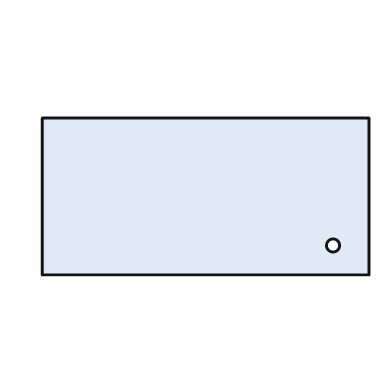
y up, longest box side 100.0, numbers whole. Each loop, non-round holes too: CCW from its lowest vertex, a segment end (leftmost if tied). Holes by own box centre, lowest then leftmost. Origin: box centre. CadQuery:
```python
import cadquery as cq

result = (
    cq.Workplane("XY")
    .moveTo(-50.0, -24.0)
    .lineTo(50.0, -24.0)
    .lineTo(50.0, 24.0)
    .lineTo(-50.0, 24.0)
    .close()
    .moveTo(39.0, -15.0)
    .circle(2.0)
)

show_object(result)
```